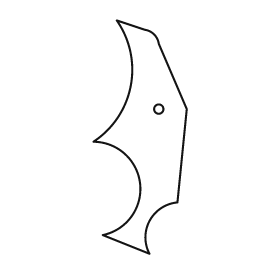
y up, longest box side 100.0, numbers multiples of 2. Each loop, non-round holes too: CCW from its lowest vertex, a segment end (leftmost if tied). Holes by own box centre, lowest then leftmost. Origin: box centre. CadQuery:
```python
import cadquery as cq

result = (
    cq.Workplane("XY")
    .moveTo(4.0, -50.0)
    .threePointArc((4.0, -36.0), (16.0, -28.0))
    .lineTo(20.0, 12.0)
    .lineTo(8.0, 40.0)
    .threePointArc((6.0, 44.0), (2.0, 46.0))
    .lineTo(-10.0, 50.0)
    .threePointArc((-4.0, 22.0), (-20.0, -2.0))
    .threePointArc((0.0, -20.0), (-16.0, -42.0))
    .close()
    .moveTo(8.0, 12.0)
    .circle(2.0)
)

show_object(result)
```